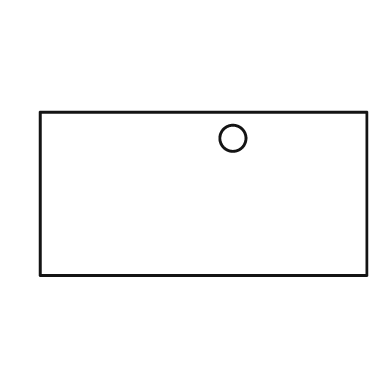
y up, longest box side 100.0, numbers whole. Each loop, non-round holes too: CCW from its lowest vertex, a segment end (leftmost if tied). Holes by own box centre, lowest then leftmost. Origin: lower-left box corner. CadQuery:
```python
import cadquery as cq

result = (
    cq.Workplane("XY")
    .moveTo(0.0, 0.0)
    .lineTo(100.0, 0.0)
    .lineTo(100.0, 50.0)
    .lineTo(0.0, 50.0)
    .close()
    .moveTo(59.0, 42.0)
    .circle(4.0)
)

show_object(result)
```